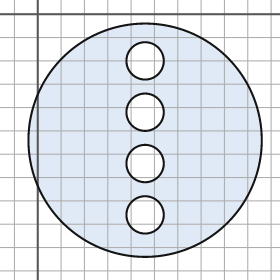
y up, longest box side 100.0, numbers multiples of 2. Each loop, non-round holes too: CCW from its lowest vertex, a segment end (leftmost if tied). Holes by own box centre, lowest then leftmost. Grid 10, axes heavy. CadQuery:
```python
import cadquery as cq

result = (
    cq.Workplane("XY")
    .moveTo(46.0, -54.0)
    .circle(50.0)
    .moveTo(46.0, -86.0)
    .circle(8.0)
    .moveTo(46.0, -64.0)
    .circle(8.0)
    .moveTo(46.0, -42.0)
    .circle(8.0)
    .moveTo(46.0, -20.0)
    .circle(8.0)
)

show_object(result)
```